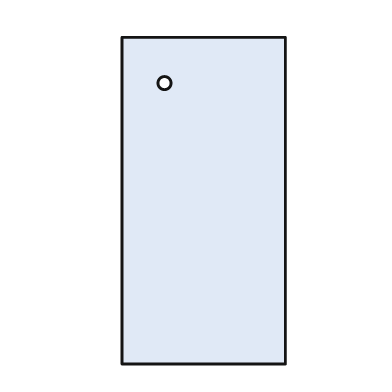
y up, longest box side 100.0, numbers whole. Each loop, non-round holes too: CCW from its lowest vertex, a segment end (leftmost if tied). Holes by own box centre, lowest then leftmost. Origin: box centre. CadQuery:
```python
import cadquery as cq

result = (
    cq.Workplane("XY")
    .moveTo(-25.0, -50.0)
    .lineTo(25.0, -50.0)
    .lineTo(25.0, 50.0)
    .lineTo(-25.0, 50.0)
    .close()
    .moveTo(-12.0, 36.0)
    .circle(2.0)
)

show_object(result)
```